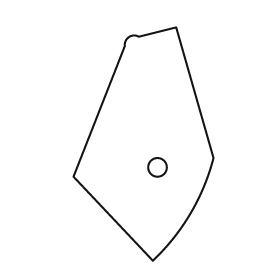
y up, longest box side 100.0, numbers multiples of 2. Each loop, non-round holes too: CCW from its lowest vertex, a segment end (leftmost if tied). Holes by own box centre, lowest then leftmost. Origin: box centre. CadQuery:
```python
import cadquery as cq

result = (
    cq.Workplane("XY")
    .moveTo(4.0, -50.0)
    .threePointArc((20.0, -30.0), (30.0, -6.0))
    .lineTo(14.0, 50.0)
    .lineTo(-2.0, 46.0)
    .threePointArc((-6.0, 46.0), (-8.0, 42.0))
    .lineTo(-30.0, -14.0)
    .close()
    .moveTo(6.0, -10.0)
    .circle(4.0)
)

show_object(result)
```